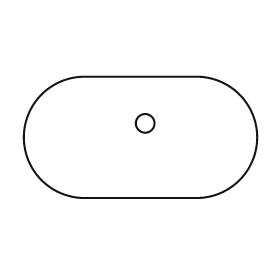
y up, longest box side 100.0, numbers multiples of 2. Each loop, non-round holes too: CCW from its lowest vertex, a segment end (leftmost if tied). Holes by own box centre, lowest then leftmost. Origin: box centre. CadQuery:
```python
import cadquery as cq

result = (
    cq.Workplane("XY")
    .moveTo(-24.0, -26.0)
    .lineTo(24.0, -26.0)
    .threePointArc((50.0, 0.0), (24.0, 26.0))
    .lineTo(-24.0, 26.0)
    .threePointArc((-50.0, 0.0), (-24.0, -26.0))
    .close()
    .moveTo(2.0, 6.0)
    .circle(4.0)
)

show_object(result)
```